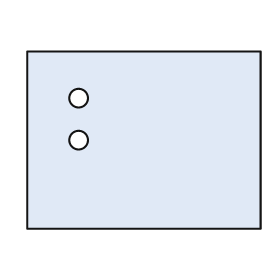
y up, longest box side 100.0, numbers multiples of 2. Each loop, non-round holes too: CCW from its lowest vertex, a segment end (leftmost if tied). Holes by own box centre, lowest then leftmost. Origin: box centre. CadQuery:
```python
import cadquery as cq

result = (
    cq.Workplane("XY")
    .moveTo(-50.0, -38.0)
    .lineTo(50.0, -38.0)
    .lineTo(50.0, 38.0)
    .lineTo(-50.0, 38.0)
    .close()
    .moveTo(-28.0, 0.0)
    .circle(4.0)
    .moveTo(-28.0, 18.0)
    .circle(4.0)
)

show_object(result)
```